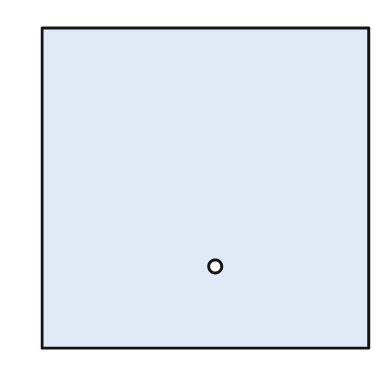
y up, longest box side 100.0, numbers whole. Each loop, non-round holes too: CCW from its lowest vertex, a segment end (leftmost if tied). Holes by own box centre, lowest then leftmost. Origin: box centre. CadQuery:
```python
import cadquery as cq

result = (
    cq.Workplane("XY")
    .moveTo(-50.0, -49.0)
    .lineTo(50.0, -49.0)
    .lineTo(50.0, 49.0)
    .lineTo(-50.0, 49.0)
    .close()
    .moveTo(3.0, -24.0)
    .circle(2.0)
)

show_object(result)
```